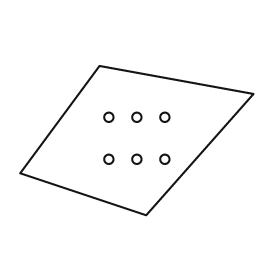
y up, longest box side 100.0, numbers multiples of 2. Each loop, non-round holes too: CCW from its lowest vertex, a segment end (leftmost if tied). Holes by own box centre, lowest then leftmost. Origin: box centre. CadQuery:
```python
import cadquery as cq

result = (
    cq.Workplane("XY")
    .moveTo(4.0, -32.0)
    .lineTo(50.0, 20.0)
    .lineTo(-16.0, 32.0)
    .lineTo(-50.0, -14.0)
    .close()
    .moveTo(-12.0, -8.0)
    .circle(2.0)
    .moveTo(0.0, -8.0)
    .circle(2.0)
    .moveTo(12.0, -8.0)
    .circle(2.0)
    .moveTo(-12.0, 10.0)
    .circle(2.0)
    .moveTo(0.0, 10.0)
    .circle(2.0)
    .moveTo(12.0, 10.0)
    .circle(2.0)
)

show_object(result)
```